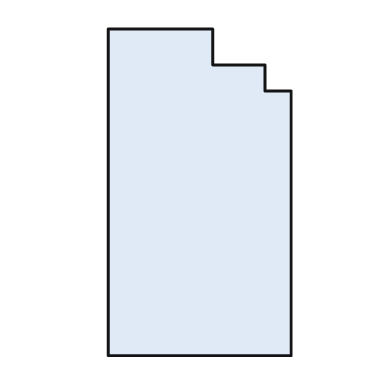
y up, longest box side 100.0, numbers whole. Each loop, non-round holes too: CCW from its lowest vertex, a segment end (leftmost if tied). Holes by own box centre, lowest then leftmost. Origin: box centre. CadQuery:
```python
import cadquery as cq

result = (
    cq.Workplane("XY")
    .moveTo(-28.0, -50.0)
    .lineTo(28.0, -50.0)
    .lineTo(28.0, 31.0)
    .lineTo(20.0, 31.0)
    .lineTo(20.0, 39.0)
    .lineTo(4.0, 39.0)
    .lineTo(4.0, 50.0)
    .lineTo(-28.0, 50.0)
    .close()
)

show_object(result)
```